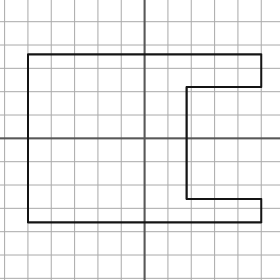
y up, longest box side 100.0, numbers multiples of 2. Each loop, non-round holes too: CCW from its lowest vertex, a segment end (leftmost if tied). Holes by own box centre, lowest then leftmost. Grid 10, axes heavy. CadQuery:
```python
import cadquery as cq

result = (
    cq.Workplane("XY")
    .moveTo(-50.0, -36.0)
    .lineTo(50.0, -36.0)
    .lineTo(50.0, -26.0)
    .lineTo(18.0, -26.0)
    .lineTo(18.0, 22.0)
    .lineTo(50.0, 22.0)
    .lineTo(50.0, 36.0)
    .lineTo(-50.0, 36.0)
    .close()
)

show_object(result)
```